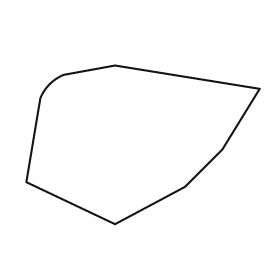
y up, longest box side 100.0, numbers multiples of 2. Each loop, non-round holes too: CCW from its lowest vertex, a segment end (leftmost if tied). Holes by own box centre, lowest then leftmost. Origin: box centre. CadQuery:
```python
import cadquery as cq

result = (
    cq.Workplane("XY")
    .moveTo(-12.0, -34.0)
    .lineTo(18.0, -18.0)
    .lineTo(34.0, -2.0)
    .lineTo(50.0, 24.0)
    .lineTo(-12.0, 34.0)
    .lineTo(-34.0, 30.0)
    .threePointArc((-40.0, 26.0), (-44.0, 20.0))
    .lineTo(-50.0, -16.0)
    .close()
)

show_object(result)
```